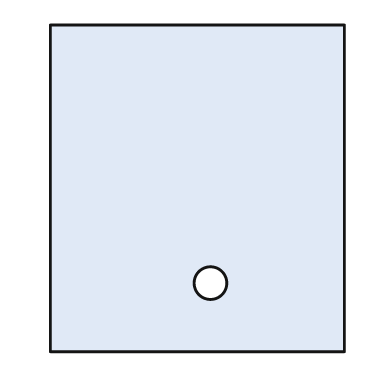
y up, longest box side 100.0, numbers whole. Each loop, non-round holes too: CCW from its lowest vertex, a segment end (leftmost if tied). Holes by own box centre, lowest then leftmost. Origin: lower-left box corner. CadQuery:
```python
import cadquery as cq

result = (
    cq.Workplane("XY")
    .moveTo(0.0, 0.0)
    .lineTo(90.0, 0.0)
    .lineTo(90.0, 100.0)
    .lineTo(0.0, 100.0)
    .close()
    .moveTo(49.0, 21.0)
    .circle(5.0)
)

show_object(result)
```